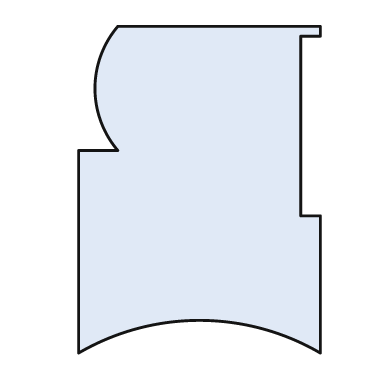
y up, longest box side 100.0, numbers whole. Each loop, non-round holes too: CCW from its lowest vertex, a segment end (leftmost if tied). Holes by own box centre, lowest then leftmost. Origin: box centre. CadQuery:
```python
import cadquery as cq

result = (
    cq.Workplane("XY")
    .moveTo(-37.0, -50.0)
    .threePointArc((0.0, -40.0), (37.0, -50.0))
    .lineTo(37.0, -8.0)
    .lineTo(31.0, -8.0)
    .lineTo(31.0, 47.0)
    .lineTo(37.0, 47.0)
    .lineTo(37.0, 50.0)
    .lineTo(-25.0, 50.0)
    .threePointArc((-32.0, 31.0), (-25.0, 12.0))
    .lineTo(-37.0, 12.0)
    .close()
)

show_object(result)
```